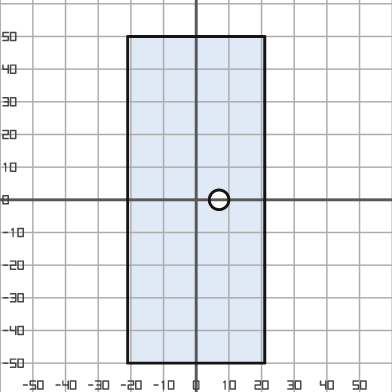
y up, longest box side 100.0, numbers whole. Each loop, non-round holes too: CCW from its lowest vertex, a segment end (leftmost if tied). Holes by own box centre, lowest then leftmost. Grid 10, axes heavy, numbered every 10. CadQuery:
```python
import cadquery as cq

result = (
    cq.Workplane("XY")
    .moveTo(-21.0, -50.0)
    .lineTo(21.0, -50.0)
    .lineTo(21.0, 50.0)
    .lineTo(-21.0, 50.0)
    .close()
    .moveTo(7.0, 0.0)
    .circle(3.0)
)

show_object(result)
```